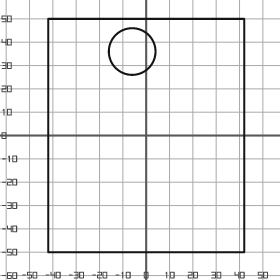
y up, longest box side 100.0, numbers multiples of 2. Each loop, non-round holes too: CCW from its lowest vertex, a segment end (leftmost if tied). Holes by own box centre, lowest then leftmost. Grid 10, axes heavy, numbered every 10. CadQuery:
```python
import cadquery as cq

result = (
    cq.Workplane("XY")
    .moveTo(-42.0, -50.0)
    .lineTo(42.0, -50.0)
    .lineTo(42.0, 50.0)
    .lineTo(-42.0, 50.0)
    .close()
    .moveTo(-6.0, 36.0)
    .circle(10.0)
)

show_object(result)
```